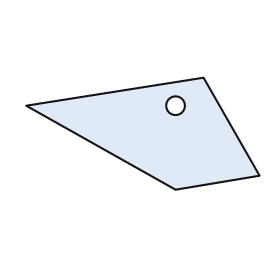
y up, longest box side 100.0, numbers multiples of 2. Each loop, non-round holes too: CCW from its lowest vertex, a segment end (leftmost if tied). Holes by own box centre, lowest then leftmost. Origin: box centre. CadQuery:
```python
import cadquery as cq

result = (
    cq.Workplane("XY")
    .moveTo(14.0, -24.0)
    .lineTo(50.0, -18.0)
    .lineTo(26.0, 24.0)
    .lineTo(-50.0, 12.0)
    .close()
    .moveTo(14.0, 12.0)
    .circle(4.0)
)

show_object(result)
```